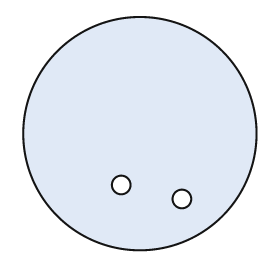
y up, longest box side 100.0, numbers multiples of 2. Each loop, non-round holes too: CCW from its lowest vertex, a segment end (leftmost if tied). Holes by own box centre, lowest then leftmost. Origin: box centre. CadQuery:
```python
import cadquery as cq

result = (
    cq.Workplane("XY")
    .moveTo(0.0, 0.0)
    .circle(50.0)
    .moveTo(18.0, -28.0)
    .circle(4.0)
    .moveTo(-8.0, -22.0)
    .circle(4.0)
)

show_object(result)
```